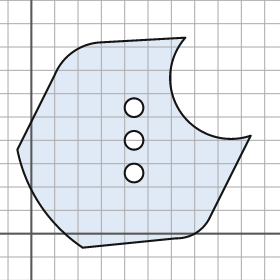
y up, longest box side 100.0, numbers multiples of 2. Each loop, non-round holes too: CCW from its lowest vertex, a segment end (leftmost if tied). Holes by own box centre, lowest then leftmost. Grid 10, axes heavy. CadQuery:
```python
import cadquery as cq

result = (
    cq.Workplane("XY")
    .moveTo(22.0, -6.0)
    .lineTo(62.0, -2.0)
    .threePointArc((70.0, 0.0), (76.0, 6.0))
    .lineTo(94.0, 42.0)
    .threePointArc((64.0, 52.0), (66.0, 84.0))
    .lineTo(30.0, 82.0)
    .threePointArc((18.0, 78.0), (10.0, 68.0))
    .lineTo(-6.0, 36.0)
    .threePointArc((4.0, 12.0), (22.0, -6.0))
    .close()
    .moveTo(44.0, 26.0)
    .circle(4.0)
    .moveTo(44.0, 40.0)
    .circle(4.0)
    .moveTo(44.0, 54.0)
    .circle(4.0)
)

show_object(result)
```